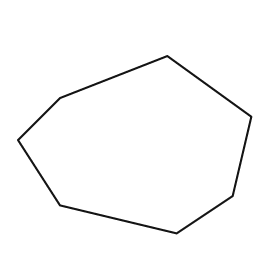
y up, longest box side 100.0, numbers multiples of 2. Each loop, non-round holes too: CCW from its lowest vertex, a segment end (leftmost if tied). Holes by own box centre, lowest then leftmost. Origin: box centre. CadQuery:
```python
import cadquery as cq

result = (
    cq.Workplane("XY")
    .moveTo(18.0, -38.0)
    .lineTo(42.0, -22.0)
    .lineTo(50.0, 12.0)
    .lineTo(14.0, 38.0)
    .lineTo(-32.0, 20.0)
    .lineTo(-50.0, 2.0)
    .lineTo(-32.0, -26.0)
    .close()
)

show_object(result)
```